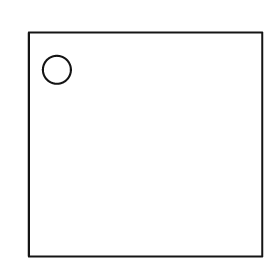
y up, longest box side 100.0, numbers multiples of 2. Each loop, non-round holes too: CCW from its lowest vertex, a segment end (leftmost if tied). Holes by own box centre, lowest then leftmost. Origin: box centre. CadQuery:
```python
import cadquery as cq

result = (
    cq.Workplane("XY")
    .moveTo(-50.0, -48.0)
    .lineTo(50.0, -48.0)
    .lineTo(50.0, 48.0)
    .lineTo(-50.0, 48.0)
    .close()
    .moveTo(-38.0, 32.0)
    .circle(6.0)
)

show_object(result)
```